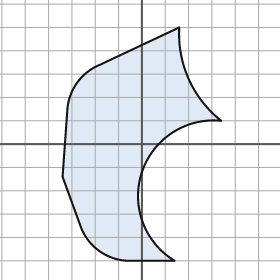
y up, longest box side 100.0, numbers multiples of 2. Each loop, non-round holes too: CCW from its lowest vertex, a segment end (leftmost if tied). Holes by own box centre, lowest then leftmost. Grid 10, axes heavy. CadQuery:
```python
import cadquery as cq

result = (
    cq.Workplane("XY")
    .moveTo(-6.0, -50.0)
    .lineTo(14.0, -50.0)
    .threePointArc((0.0, -12.0), (34.0, 10.0))
    .threePointArc((20.0, 28.0), (16.0, 50.0))
    .lineTo(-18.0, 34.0)
    .threePointArc((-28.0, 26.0), (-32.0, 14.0))
    .lineTo(-34.0, -14.0)
    .lineTo(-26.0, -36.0)
    .threePointArc((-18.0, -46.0), (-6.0, -50.0))
    .close()
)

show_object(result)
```